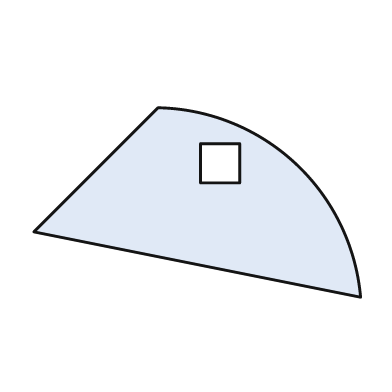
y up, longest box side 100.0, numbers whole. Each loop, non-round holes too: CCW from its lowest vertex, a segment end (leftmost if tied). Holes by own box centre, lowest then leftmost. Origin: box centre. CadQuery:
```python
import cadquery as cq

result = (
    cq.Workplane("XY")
    .moveTo(50.0, -29.0)
    .threePointArc((30.0, 12.0), (-12.0, 29.0))
    .lineTo(-50.0, -9.0)
    .close()
    .moveTo(1.0, 6.0)
    .lineTo(13.0, 6.0)
    .lineTo(13.0, 18.0)
    .lineTo(1.0, 18.0)
    .close()
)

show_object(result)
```